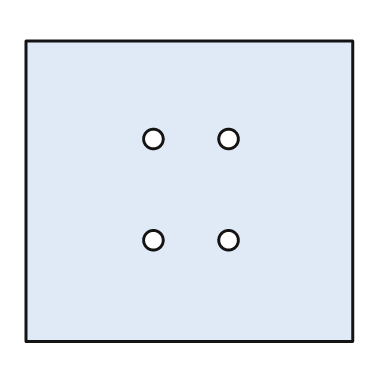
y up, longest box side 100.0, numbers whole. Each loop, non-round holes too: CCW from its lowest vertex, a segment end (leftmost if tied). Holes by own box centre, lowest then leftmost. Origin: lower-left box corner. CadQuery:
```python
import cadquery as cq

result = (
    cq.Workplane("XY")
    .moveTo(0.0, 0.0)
    .lineTo(100.0, 0.0)
    .lineTo(100.0, 92.0)
    .lineTo(0.0, 92.0)
    .close()
    .moveTo(39.0, 31.0)
    .circle(3.0)
    .moveTo(62.0, 31.0)
    .circle(3.0)
    .moveTo(39.0, 62.0)
    .circle(3.0)
    .moveTo(62.0, 62.0)
    .circle(3.0)
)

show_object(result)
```